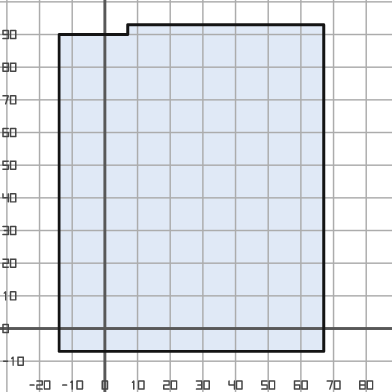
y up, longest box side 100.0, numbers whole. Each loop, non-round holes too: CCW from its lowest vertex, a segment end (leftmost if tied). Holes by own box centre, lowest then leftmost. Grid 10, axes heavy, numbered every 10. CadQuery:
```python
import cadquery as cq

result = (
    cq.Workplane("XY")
    .moveTo(-14.0, -7.0)
    .lineTo(67.0, -7.0)
    .lineTo(67.0, 93.0)
    .lineTo(7.0, 93.0)
    .lineTo(7.0, 90.0)
    .lineTo(-14.0, 90.0)
    .close()
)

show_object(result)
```